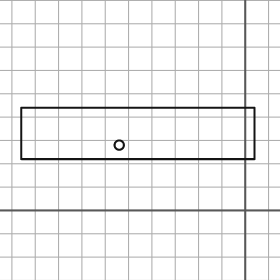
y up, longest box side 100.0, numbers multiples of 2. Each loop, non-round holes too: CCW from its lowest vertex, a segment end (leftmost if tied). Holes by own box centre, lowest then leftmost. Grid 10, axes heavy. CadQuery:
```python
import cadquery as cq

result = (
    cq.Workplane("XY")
    .moveTo(-96.0, 22.0)
    .lineTo(4.0, 22.0)
    .lineTo(4.0, 44.0)
    .lineTo(-96.0, 44.0)
    .close()
    .moveTo(-54.0, 28.0)
    .circle(2.0)
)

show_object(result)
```